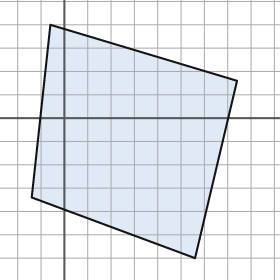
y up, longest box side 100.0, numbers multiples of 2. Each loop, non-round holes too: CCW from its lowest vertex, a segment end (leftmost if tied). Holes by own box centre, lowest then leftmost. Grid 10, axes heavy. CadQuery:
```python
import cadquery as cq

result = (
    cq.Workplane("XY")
    .moveTo(56.0, -60.0)
    .lineTo(74.0, 16.0)
    .lineTo(-6.0, 40.0)
    .lineTo(-14.0, -34.0)
    .close()
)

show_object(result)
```